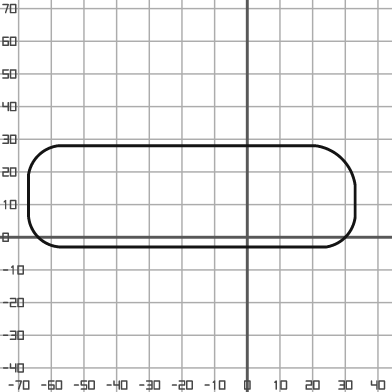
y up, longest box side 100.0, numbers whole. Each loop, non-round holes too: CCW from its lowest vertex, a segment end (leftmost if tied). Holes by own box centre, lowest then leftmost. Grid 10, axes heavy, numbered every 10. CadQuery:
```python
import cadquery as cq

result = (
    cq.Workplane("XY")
    .moveTo(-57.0, -3.0)
    .lineTo(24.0, -3.0)
    .threePointArc((30.0, 0.0), (33.0, 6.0))
    .lineTo(33.0, 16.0)
    .threePointArc((29.0, 24.0), (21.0, 28.0))
    .lineTo(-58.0, 28.0)
    .threePointArc((-64.0, 25.0), (-67.0, 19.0))
    .lineTo(-67.0, 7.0)
    .threePointArc((-64.0, 0.0), (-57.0, -3.0))
    .close()
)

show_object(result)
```